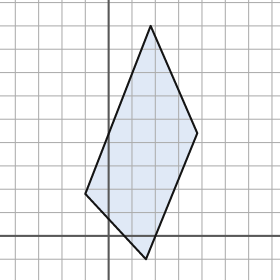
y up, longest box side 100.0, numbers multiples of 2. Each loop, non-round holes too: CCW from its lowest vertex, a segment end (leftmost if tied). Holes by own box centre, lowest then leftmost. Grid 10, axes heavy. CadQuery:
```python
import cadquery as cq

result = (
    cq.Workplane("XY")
    .moveTo(16.0, -10.0)
    .lineTo(38.0, 44.0)
    .lineTo(18.0, 90.0)
    .lineTo(-10.0, 18.0)
    .close()
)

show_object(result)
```